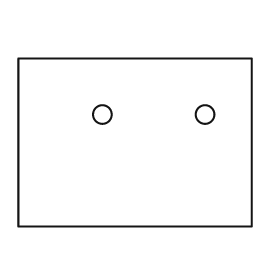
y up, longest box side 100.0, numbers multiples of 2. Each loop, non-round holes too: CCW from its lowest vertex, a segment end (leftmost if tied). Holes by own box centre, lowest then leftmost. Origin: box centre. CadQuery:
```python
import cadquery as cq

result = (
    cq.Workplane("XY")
    .moveTo(-50.0, -36.0)
    .lineTo(50.0, -36.0)
    .lineTo(50.0, 36.0)
    .lineTo(-50.0, 36.0)
    .close()
    .moveTo(-14.0, 12.0)
    .circle(4.0)
    .moveTo(30.0, 12.0)
    .circle(4.0)
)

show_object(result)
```